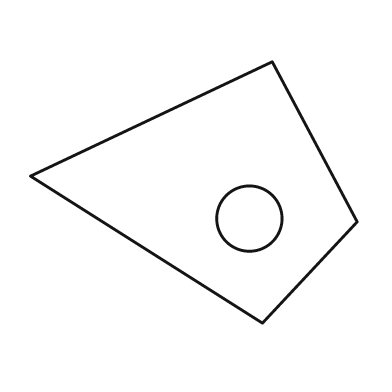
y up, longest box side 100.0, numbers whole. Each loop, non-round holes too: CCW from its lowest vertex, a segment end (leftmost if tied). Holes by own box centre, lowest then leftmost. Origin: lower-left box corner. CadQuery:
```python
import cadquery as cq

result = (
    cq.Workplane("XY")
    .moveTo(71.0, 0.0)
    .lineTo(100.0, 31.0)
    .lineTo(74.0, 80.0)
    .lineTo(0.0, 45.0)
    .close()
    .moveTo(67.0, 32.0)
    .circle(10.0)
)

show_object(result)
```